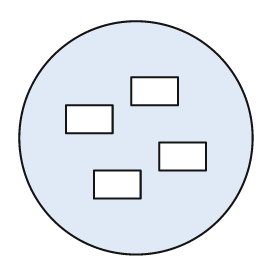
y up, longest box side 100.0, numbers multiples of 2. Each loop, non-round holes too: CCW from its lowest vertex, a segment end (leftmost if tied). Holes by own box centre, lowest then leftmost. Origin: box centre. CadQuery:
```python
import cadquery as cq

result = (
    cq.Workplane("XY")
    .moveTo(0.0, 0.0)
    .circle(50.0)
    .moveTo(-18.0, -26.0)
    .lineTo(2.0, -26.0)
    .lineTo(2.0, -14.0)
    .lineTo(-18.0, -14.0)
    .close()
    .moveTo(10.0, -14.0)
    .lineTo(30.0, -14.0)
    .lineTo(30.0, -2.0)
    .lineTo(10.0, -2.0)
    .close()
    .moveTo(-30.0, 2.0)
    .lineTo(-10.0, 2.0)
    .lineTo(-10.0, 14.0)
    .lineTo(-30.0, 14.0)
    .close()
    .moveTo(-2.0, 14.0)
    .lineTo(18.0, 14.0)
    .lineTo(18.0, 26.0)
    .lineTo(-2.0, 26.0)
    .close()
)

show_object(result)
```